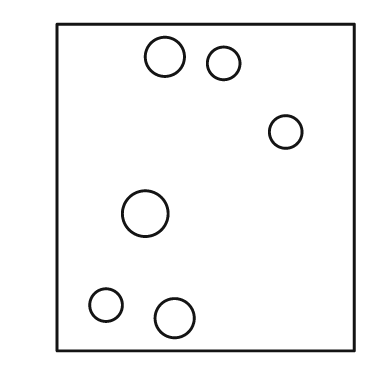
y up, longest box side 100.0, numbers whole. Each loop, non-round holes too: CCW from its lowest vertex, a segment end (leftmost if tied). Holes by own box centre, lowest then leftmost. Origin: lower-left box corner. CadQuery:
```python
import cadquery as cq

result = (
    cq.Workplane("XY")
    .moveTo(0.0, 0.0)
    .lineTo(91.0, 0.0)
    .lineTo(91.0, 100.0)
    .lineTo(0.0, 100.0)
    .close()
    .moveTo(36.0, 10.0)
    .circle(6.0)
    .moveTo(15.0, 14.0)
    .circle(5.0)
    .moveTo(27.0, 42.0)
    .circle(7.0)
    .moveTo(70.0, 67.0)
    .circle(5.0)
    .moveTo(51.0, 88.0)
    .circle(5.0)
    .moveTo(33.0, 90.0)
    .circle(6.0)
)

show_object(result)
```